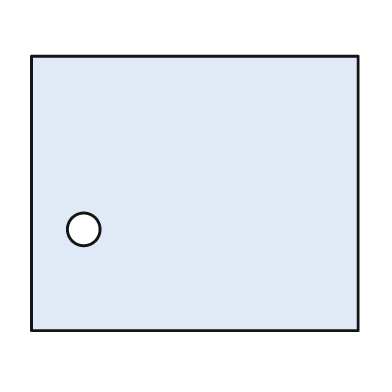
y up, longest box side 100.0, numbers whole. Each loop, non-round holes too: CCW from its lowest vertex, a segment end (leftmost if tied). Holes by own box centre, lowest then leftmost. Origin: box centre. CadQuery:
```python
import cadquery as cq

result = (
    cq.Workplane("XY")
    .moveTo(-50.0, -42.0)
    .lineTo(50.0, -42.0)
    .lineTo(50.0, 42.0)
    .lineTo(-50.0, 42.0)
    .close()
    .moveTo(-34.0, -11.0)
    .circle(5.0)
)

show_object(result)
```